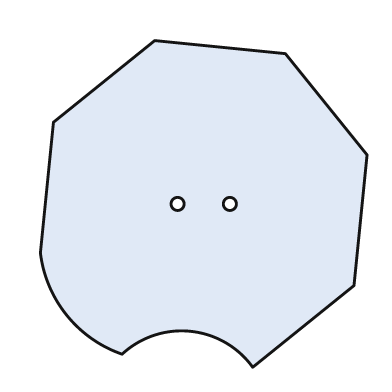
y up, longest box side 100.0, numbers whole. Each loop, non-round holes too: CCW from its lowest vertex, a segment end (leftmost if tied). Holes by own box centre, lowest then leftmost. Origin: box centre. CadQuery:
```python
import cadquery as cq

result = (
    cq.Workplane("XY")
    .moveTo(15.0, -50.0)
    .lineTo(46.0, -25.0)
    .lineTo(50.0, 15.0)
    .lineTo(25.0, 46.0)
    .lineTo(-15.0, 50.0)
    .lineTo(-46.0, 25.0)
    .lineTo(-50.0, -15.0)
    .threePointArc((-42.0, -34.0), (-25.0, -46.0))
    .threePointArc((-4.0, -39.0), (15.0, -50.0))
    .close()
    .moveTo(-8.0, 0.0)
    .circle(2.0)
    .moveTo(8.0, 0.0)
    .circle(2.0)
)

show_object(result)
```